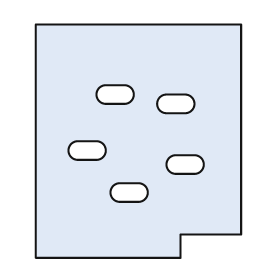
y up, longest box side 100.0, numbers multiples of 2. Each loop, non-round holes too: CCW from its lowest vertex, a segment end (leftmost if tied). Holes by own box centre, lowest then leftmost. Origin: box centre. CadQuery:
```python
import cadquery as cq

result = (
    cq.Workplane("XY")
    .moveTo(-44.0, -50.0)
    .lineTo(18.0, -50.0)
    .lineTo(18.0, -40.0)
    .lineTo(44.0, -40.0)
    .lineTo(44.0, 50.0)
    .lineTo(-44.0, 50.0)
    .close()
    .moveTo(-8.0, -26.0)
    .lineTo(0.0, -26.0)
    .threePointArc((4.0, -22.0), (0.0, -18.0))
    .lineTo(-8.0, -18.0)
    .threePointArc((-12.0, -22.0), (-8.0, -26.0))
    .close()
    .moveTo(16.0, -14.0)
    .lineTo(24.0, -14.0)
    .threePointArc((28.0, -10.0), (24.0, -6.0))
    .lineTo(16.0, -6.0)
    .threePointArc((12.0, -10.0), (16.0, -14.0))
    .close()
    .moveTo(-26.0, -8.0)
    .lineTo(-18.0, -8.0)
    .threePointArc((-14.0, -4.0), (-18.0, 0.0))
    .lineTo(-26.0, 0.0)
    .threePointArc((-30.0, -4.0), (-26.0, -8.0))
    .close()
    .moveTo(12.0, 12.0)
    .lineTo(20.0, 12.0)
    .threePointArc((24.0, 16.0), (20.0, 20.0))
    .lineTo(12.0, 20.0)
    .threePointArc((8.0, 16.0), (12.0, 12.0))
    .close()
    .moveTo(-14.0, 16.0)
    .lineTo(-6.0, 16.0)
    .threePointArc((-2.0, 20.0), (-6.0, 24.0))
    .lineTo(-14.0, 24.0)
    .threePointArc((-18.0, 20.0), (-14.0, 16.0))
    .close()
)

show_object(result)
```